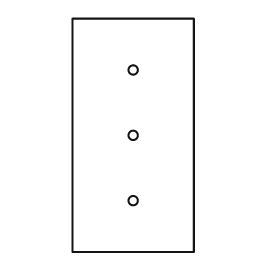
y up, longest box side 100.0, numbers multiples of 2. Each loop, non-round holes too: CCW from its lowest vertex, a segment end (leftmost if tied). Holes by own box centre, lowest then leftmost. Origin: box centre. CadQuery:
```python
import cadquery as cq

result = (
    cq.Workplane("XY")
    .moveTo(-26.0, -50.0)
    .lineTo(26.0, -50.0)
    .lineTo(26.0, 50.0)
    .lineTo(-26.0, 50.0)
    .close()
    .moveTo(0.0, -28.0)
    .circle(2.0)
    .moveTo(0.0, 0.0)
    .circle(2.0)
    .moveTo(0.0, 28.0)
    .circle(2.0)
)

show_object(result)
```